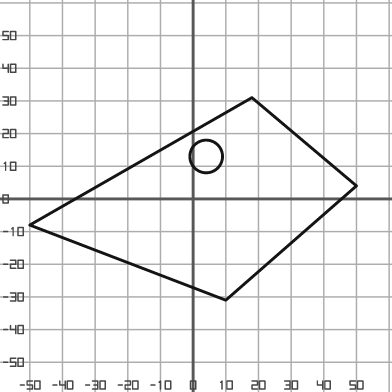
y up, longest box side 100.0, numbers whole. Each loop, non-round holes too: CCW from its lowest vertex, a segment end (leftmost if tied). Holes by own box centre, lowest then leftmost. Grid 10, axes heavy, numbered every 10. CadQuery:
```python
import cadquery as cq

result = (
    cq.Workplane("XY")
    .moveTo(10.0, -31.0)
    .lineTo(50.0, 4.0)
    .lineTo(18.0, 31.0)
    .lineTo(-50.0, -8.0)
    .close()
    .moveTo(4.0, 13.0)
    .circle(5.0)
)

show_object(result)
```